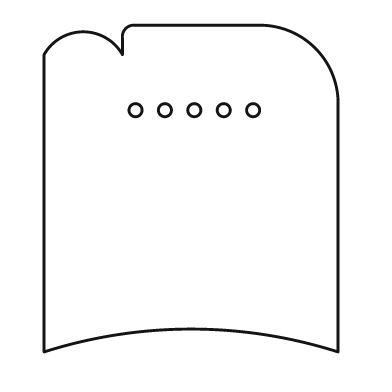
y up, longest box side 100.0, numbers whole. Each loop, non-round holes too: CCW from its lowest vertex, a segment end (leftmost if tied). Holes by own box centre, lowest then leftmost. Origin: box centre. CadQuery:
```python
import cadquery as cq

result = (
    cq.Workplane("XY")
    .moveTo(-45.0, -50.0)
    .threePointArc((0.0, -43.0), (45.0, -50.0))
    .lineTo(45.0, 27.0)
    .threePointArc((38.0, 43.0), (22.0, 50.0))
    .lineTo(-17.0, 50.0)
    .threePointArc((-20.0, 49.0), (-21.0, 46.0))
    .lineTo(-21.0, 41.0)
    .threePointArc((-33.0, 48.0), (-45.0, 41.0))
    .close()
    .moveTo(-17.0, 24.0)
    .circle(2.0)
    .moveTo(-8.0, 24.0)
    .circle(2.0)
    .moveTo(1.0, 24.0)
    .circle(2.0)
    .moveTo(10.0, 24.0)
    .circle(2.0)
    .moveTo(19.0, 24.0)
    .circle(2.0)
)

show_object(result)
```